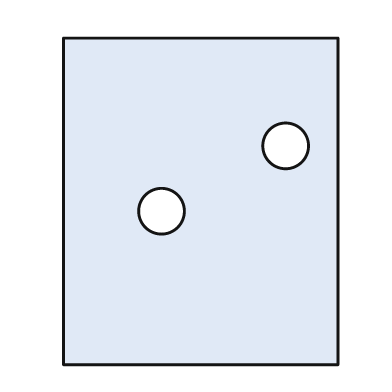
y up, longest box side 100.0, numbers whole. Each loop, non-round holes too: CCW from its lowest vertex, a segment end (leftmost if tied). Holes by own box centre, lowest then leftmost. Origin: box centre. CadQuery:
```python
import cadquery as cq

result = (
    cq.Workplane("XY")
    .moveTo(-42.0, -50.0)
    .lineTo(42.0, -50.0)
    .lineTo(42.0, 50.0)
    .lineTo(-42.0, 50.0)
    .close()
    .moveTo(-12.0, -3.0)
    .circle(7.0)
    .moveTo(26.0, 17.0)
    .circle(7.0)
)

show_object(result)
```